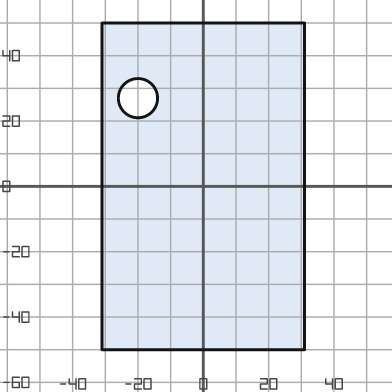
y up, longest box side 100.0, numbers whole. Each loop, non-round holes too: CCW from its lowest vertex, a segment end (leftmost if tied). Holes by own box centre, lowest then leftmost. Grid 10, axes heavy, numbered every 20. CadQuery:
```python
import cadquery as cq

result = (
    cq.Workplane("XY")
    .moveTo(-31.0, -50.0)
    .lineTo(31.0, -50.0)
    .lineTo(31.0, 50.0)
    .lineTo(-31.0, 50.0)
    .close()
    .moveTo(-20.0, 27.0)
    .circle(6.0)
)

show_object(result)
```